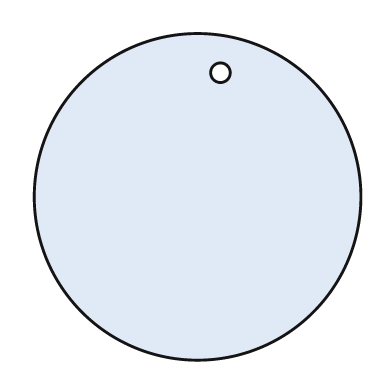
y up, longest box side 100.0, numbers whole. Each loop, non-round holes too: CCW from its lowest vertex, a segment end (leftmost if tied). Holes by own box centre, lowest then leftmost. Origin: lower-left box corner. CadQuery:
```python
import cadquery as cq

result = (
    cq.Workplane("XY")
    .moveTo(50.0, 50.0)
    .circle(50.0)
    .moveTo(57.0, 88.0)
    .circle(3.0)
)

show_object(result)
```